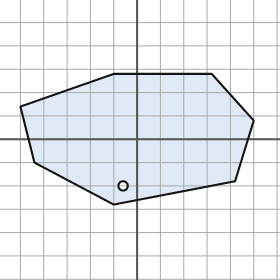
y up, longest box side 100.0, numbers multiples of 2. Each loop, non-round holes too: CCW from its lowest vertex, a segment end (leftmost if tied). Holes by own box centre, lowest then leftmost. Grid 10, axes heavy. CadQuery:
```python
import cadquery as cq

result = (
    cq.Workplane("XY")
    .moveTo(-10.0, -28.0)
    .lineTo(42.0, -18.0)
    .lineTo(50.0, 8.0)
    .lineTo(32.0, 28.0)
    .lineTo(-10.0, 28.0)
    .lineTo(-50.0, 14.0)
    .lineTo(-44.0, -10.0)
    .close()
    .moveTo(-6.0, -20.0)
    .circle(2.0)
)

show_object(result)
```